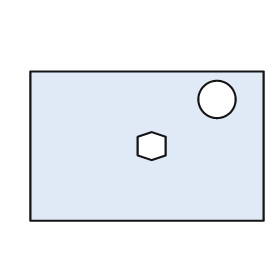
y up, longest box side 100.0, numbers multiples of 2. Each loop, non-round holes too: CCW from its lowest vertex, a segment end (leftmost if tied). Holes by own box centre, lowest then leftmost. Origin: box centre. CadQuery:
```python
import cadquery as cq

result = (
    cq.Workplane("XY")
    .moveTo(-50.0, -32.0)
    .lineTo(50.0, -32.0)
    .lineTo(50.0, 32.0)
    .lineTo(-50.0, 32.0)
    .close()
    .moveTo(2.0, -6.0)
    .lineTo(8.0, -4.0)
    .lineTo(8.0, 4.0)
    .lineTo(2.0, 6.0)
    .lineTo(-4.0, 4.0)
    .lineTo(-4.0, -4.0)
    .close()
    .moveTo(30.0, 20.0)
    .circle(8.0)
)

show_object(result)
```